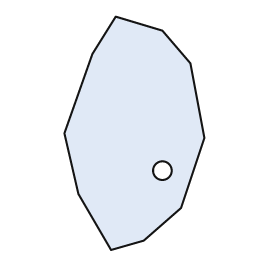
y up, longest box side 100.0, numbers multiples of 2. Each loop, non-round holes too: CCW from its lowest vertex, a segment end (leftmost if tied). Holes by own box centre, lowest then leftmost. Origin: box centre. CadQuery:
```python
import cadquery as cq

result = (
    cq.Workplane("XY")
    .moveTo(-10.0, -50.0)
    .lineTo(4.0, -46.0)
    .lineTo(20.0, -32.0)
    .lineTo(30.0, -2.0)
    .lineTo(24.0, 30.0)
    .lineTo(12.0, 44.0)
    .lineTo(-8.0, 50.0)
    .lineTo(-18.0, 34.0)
    .lineTo(-30.0, 0.0)
    .lineTo(-24.0, -26.0)
    .close()
    .moveTo(12.0, -16.0)
    .circle(4.0)
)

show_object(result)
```